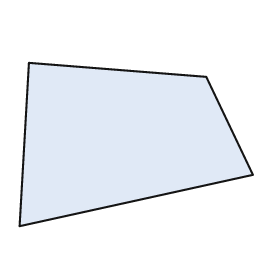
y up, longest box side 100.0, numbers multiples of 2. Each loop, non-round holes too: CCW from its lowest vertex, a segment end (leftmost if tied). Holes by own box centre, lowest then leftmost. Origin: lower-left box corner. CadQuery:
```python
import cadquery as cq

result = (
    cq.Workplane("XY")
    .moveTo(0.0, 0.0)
    .lineTo(100.0, 22.0)
    .lineTo(80.0, 64.0)
    .lineTo(4.0, 70.0)
    .close()
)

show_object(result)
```